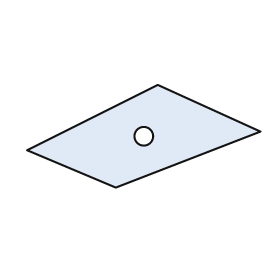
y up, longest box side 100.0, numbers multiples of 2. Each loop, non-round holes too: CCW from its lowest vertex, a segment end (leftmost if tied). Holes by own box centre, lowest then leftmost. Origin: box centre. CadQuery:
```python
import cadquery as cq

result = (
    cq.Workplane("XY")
    .moveTo(-12.0, -22.0)
    .lineTo(50.0, 2.0)
    .lineTo(6.0, 22.0)
    .lineTo(-50.0, -6.0)
    .close()
    .moveTo(0.0, 0.0)
    .circle(4.0)
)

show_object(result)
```